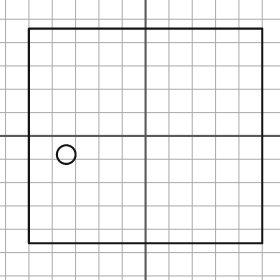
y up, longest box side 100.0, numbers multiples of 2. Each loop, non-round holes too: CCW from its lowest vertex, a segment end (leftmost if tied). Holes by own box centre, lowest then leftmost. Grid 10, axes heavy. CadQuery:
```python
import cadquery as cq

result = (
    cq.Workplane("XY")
    .moveTo(-50.0, -46.0)
    .lineTo(50.0, -46.0)
    .lineTo(50.0, 46.0)
    .lineTo(-50.0, 46.0)
    .close()
    .moveTo(-34.0, -8.0)
    .circle(4.0)
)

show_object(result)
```